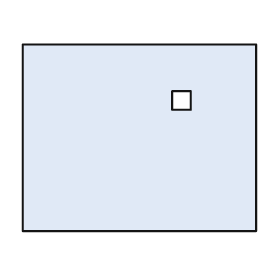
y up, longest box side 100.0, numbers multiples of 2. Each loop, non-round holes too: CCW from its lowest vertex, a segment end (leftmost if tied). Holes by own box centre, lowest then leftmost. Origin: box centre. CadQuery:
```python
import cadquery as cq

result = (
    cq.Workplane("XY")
    .moveTo(-50.0, -40.0)
    .lineTo(50.0, -40.0)
    .lineTo(50.0, 40.0)
    .lineTo(-50.0, 40.0)
    .close()
    .moveTo(14.0, 12.0)
    .lineTo(22.0, 12.0)
    .lineTo(22.0, 20.0)
    .lineTo(14.0, 20.0)
    .close()
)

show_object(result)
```